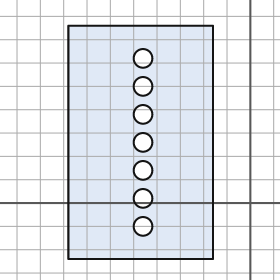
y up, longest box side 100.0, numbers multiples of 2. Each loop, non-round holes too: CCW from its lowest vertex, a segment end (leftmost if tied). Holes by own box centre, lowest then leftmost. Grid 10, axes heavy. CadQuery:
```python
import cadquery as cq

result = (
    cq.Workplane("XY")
    .moveTo(-78.0, -24.0)
    .lineTo(-16.0, -24.0)
    .lineTo(-16.0, 76.0)
    .lineTo(-78.0, 76.0)
    .close()
    .moveTo(-46.0, -10.0)
    .circle(4.0)
    .moveTo(-46.0, 2.0)
    .circle(4.0)
    .moveTo(-46.0, 14.0)
    .circle(4.0)
    .moveTo(-46.0, 26.0)
    .circle(4.0)
    .moveTo(-46.0, 38.0)
    .circle(4.0)
    .moveTo(-46.0, 50.0)
    .circle(4.0)
    .moveTo(-46.0, 62.0)
    .circle(4.0)
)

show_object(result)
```